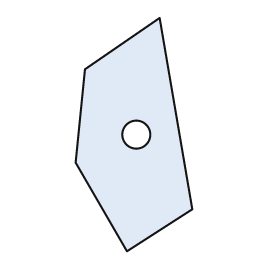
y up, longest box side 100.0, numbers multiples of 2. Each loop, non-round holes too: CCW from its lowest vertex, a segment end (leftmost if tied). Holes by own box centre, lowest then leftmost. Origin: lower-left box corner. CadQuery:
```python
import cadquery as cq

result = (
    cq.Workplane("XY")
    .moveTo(22.0, 0.0)
    .lineTo(50.0, 18.0)
    .lineTo(36.0, 100.0)
    .lineTo(4.0, 78.0)
    .lineTo(0.0, 38.0)
    .close()
    .moveTo(26.0, 50.0)
    .circle(6.0)
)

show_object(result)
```